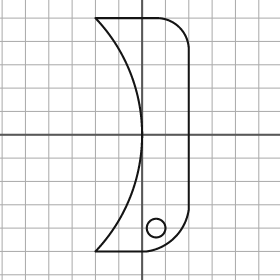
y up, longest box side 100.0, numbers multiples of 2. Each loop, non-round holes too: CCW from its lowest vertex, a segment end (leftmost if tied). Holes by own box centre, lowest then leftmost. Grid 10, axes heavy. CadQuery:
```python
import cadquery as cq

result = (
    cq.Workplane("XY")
    .moveTo(-20.0, -50.0)
    .lineTo(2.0, -50.0)
    .threePointArc((14.0, -44.0), (20.0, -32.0))
    .lineTo(20.0, 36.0)
    .threePointArc((16.0, 46.0), (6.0, 50.0))
    .lineTo(-20.0, 50.0)
    .threePointArc((0.0, 0.0), (-20.0, -50.0))
    .close()
    .moveTo(6.0, -40.0)
    .circle(4.0)
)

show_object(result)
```